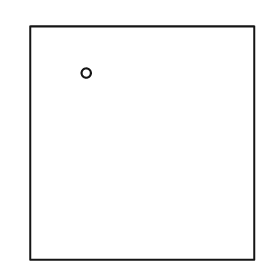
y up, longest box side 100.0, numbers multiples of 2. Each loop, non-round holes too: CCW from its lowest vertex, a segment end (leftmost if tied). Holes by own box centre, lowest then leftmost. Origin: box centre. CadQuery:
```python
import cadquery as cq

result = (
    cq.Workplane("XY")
    .moveTo(-48.0, -50.0)
    .lineTo(48.0, -50.0)
    .lineTo(48.0, 50.0)
    .lineTo(-48.0, 50.0)
    .close()
    .moveTo(-24.0, 30.0)
    .circle(2.0)
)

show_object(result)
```